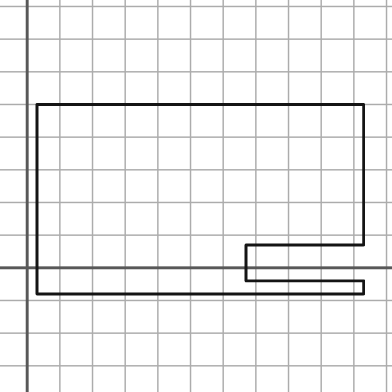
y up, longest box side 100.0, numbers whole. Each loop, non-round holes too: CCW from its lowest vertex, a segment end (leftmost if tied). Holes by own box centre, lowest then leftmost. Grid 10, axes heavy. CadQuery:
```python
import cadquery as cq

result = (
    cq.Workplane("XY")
    .moveTo(3.0, -8.0)
    .lineTo(103.0, -8.0)
    .lineTo(103.0, -4.0)
    .lineTo(67.0, -4.0)
    .lineTo(67.0, 7.0)
    .lineTo(103.0, 7.0)
    .lineTo(103.0, 50.0)
    .lineTo(3.0, 50.0)
    .close()
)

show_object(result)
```